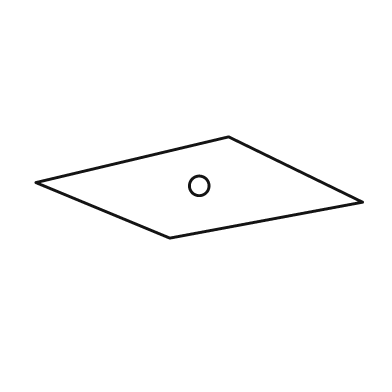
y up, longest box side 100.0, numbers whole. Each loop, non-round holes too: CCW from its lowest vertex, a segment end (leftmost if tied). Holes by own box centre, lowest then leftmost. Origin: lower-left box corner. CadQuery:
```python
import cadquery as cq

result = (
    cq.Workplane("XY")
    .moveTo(41.0, 0.0)
    .lineTo(100.0, 11.0)
    .lineTo(59.0, 31.0)
    .lineTo(0.0, 17.0)
    .close()
    .moveTo(50.0, 16.0)
    .circle(3.0)
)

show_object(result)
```